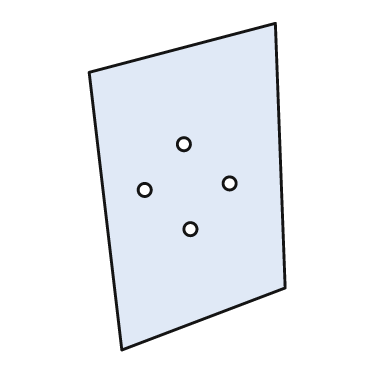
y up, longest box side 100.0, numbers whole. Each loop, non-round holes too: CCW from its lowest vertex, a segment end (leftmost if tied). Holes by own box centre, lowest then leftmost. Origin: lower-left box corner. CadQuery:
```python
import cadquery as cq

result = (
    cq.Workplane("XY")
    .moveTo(10.0, 0.0)
    .lineTo(60.0, 19.0)
    .lineTo(57.0, 100.0)
    .lineTo(0.0, 85.0)
    .close()
    .moveTo(31.0, 37.0)
    .circle(2.0)
    .moveTo(17.0, 49.0)
    .circle(2.0)
    .moveTo(43.0, 51.0)
    .circle(2.0)
    .moveTo(29.0, 63.0)
    .circle(2.0)
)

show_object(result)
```